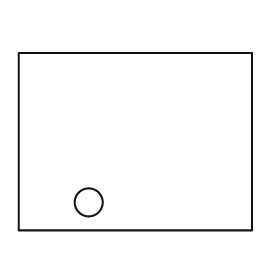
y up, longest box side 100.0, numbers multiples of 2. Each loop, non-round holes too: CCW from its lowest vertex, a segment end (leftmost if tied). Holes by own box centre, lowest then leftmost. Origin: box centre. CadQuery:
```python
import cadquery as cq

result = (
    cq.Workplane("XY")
    .moveTo(-50.0, -38.0)
    .lineTo(50.0, -38.0)
    .lineTo(50.0, 38.0)
    .lineTo(-50.0, 38.0)
    .close()
    .moveTo(-20.0, -26.0)
    .circle(6.0)
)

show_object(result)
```